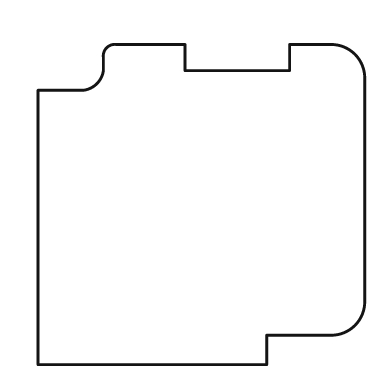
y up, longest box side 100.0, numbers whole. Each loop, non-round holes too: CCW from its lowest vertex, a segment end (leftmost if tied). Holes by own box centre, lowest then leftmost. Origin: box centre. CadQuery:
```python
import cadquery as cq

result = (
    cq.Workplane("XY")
    .moveTo(-50.0, -49.0)
    .lineTo(20.0, -49.0)
    .lineTo(20.0, -40.0)
    .lineTo(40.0, -40.0)
    .threePointArc((47.0, -37.0), (50.0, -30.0))
    .lineTo(50.0, 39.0)
    .threePointArc((47.0, 46.0), (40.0, 49.0))
    .lineTo(27.0, 49.0)
    .lineTo(27.0, 41.0)
    .lineTo(-5.0, 41.0)
    .lineTo(-5.0, 49.0)
    .lineTo(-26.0, 49.0)
    .threePointArc((-29.0, 48.0), (-30.0, 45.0))
    .lineTo(-30.0, 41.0)
    .threePointArc((-32.0, 37.0), (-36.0, 35.0))
    .lineTo(-50.0, 35.0)
    .close()
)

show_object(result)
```